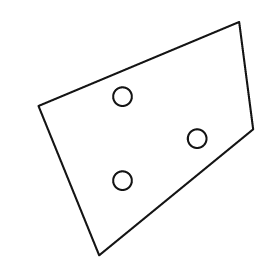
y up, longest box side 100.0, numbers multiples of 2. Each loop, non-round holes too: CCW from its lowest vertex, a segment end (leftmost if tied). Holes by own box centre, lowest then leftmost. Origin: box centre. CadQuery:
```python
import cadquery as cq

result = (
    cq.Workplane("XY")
    .moveTo(-20.0, -50.0)
    .lineTo(46.0, 4.0)
    .lineTo(40.0, 50.0)
    .lineTo(-46.0, 14.0)
    .close()
    .moveTo(-10.0, -18.0)
    .circle(4.0)
    .moveTo(22.0, 0.0)
    .circle(4.0)
    .moveTo(-10.0, 18.0)
    .circle(4.0)
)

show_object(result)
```